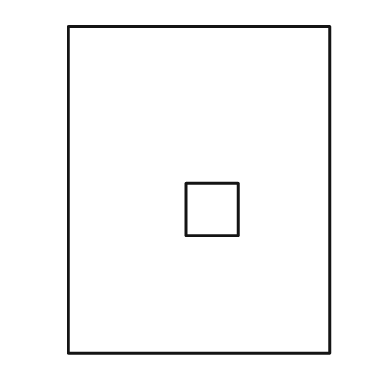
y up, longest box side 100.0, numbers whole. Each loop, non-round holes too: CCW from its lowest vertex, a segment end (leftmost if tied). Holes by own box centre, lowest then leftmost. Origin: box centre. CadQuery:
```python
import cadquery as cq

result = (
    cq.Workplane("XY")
    .moveTo(-40.0, -50.0)
    .lineTo(40.0, -50.0)
    .lineTo(40.0, 50.0)
    .lineTo(-40.0, 50.0)
    .close()
    .moveTo(-4.0, -14.0)
    .lineTo(12.0, -14.0)
    .lineTo(12.0, 2.0)
    .lineTo(-4.0, 2.0)
    .close()
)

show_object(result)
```